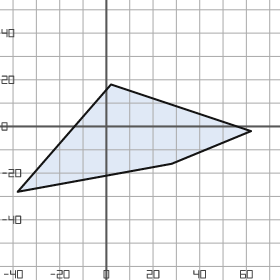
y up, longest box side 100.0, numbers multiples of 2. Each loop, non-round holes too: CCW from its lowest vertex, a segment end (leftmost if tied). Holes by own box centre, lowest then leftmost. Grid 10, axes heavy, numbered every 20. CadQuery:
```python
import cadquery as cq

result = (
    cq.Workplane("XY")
    .moveTo(-38.0, -28.0)
    .lineTo(28.0, -16.0)
    .lineTo(62.0, -2.0)
    .lineTo(2.0, 18.0)
    .close()
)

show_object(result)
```